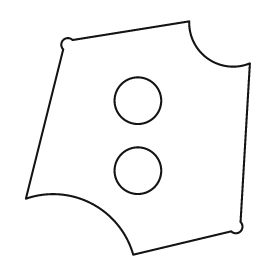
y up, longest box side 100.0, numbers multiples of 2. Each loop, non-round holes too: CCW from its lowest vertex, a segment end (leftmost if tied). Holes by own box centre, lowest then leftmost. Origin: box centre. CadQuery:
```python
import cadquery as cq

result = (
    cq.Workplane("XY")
    .moveTo(-2.0, -50.0)
    .lineTo(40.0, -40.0)
    .threePointArc((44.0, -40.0), (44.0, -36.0))
    .lineTo(48.0, 32.0)
    .threePointArc((30.0, 34.0), (22.0, 50.0))
    .lineTo(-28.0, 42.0)
    .threePointArc((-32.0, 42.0), (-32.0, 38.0))
    .lineTo(-48.0, -26.0)
    .threePointArc((-20.0, -28.0), (-2.0, -50.0))
    .close()
    .moveTo(0.0, -14.0)
    .circle(10.0)
    .moveTo(0.0, 16.0)
    .circle(10.0)
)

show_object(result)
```